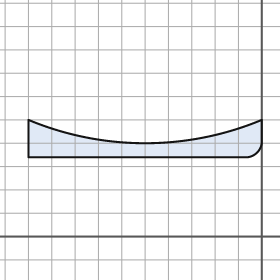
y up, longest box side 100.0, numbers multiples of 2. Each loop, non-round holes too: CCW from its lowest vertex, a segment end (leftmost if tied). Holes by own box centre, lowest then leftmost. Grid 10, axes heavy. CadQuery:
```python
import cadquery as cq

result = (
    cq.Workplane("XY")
    .moveTo(-100.0, 34.0)
    .lineTo(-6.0, 34.0)
    .threePointArc((-2.0, 36.0), (0.0, 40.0))
    .lineTo(0.0, 50.0)
    .threePointArc((-50.0, 40.0), (-100.0, 50.0))
    .close()
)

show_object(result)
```